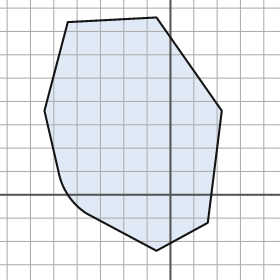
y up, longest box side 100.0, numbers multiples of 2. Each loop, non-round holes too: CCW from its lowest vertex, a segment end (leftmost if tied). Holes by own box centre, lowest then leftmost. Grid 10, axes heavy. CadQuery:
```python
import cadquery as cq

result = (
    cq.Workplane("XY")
    .moveTo(-6.0, -24.0)
    .lineTo(16.0, -12.0)
    .lineTo(22.0, 36.0)
    .lineTo(-6.0, 76.0)
    .lineTo(-44.0, 74.0)
    .lineTo(-54.0, 36.0)
    .lineTo(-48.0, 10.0)
    .threePointArc((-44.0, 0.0), (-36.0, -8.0))
    .close()
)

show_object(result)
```